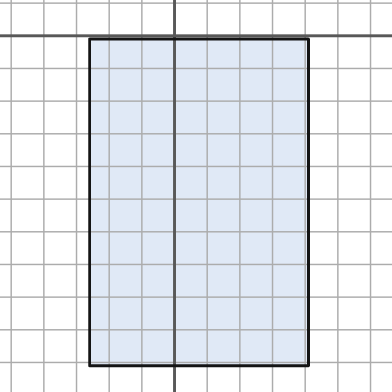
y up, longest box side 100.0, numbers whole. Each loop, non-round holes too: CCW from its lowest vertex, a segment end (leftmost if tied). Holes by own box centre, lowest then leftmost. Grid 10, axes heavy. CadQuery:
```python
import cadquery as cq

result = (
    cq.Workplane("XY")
    .moveTo(-26.0, -101.0)
    .lineTo(41.0, -101.0)
    .lineTo(41.0, -1.0)
    .lineTo(-26.0, -1.0)
    .close()
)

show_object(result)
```